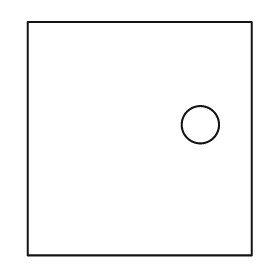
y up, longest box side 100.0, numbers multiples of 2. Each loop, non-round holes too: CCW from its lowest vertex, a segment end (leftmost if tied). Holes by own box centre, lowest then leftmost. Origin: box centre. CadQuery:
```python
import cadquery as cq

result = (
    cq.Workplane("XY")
    .moveTo(-48.0, -50.0)
    .lineTo(48.0, -50.0)
    .lineTo(48.0, 50.0)
    .lineTo(-48.0, 50.0)
    .close()
    .moveTo(26.0, 6.0)
    .circle(8.0)
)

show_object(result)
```